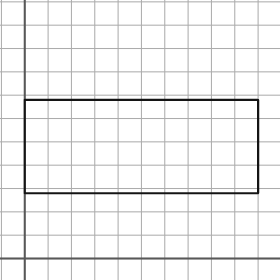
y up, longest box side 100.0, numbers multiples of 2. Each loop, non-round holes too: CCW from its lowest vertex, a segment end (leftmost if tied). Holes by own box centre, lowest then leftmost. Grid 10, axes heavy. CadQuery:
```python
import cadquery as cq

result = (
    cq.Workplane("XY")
    .moveTo(0.0, 28.0)
    .lineTo(100.0, 28.0)
    .lineTo(100.0, 68.0)
    .lineTo(0.0, 68.0)
    .close()
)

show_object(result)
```